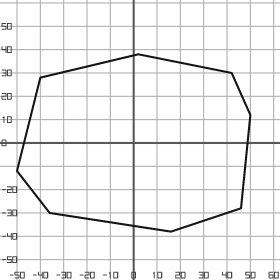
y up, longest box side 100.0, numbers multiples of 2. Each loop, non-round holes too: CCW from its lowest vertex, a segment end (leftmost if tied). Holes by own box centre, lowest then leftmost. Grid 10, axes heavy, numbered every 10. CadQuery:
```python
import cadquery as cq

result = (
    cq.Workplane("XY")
    .moveTo(16.0, -38.0)
    .lineTo(46.0, -28.0)
    .lineTo(50.0, 12.0)
    .lineTo(42.0, 30.0)
    .lineTo(2.0, 38.0)
    .lineTo(-40.0, 28.0)
    .lineTo(-50.0, -12.0)
    .lineTo(-36.0, -30.0)
    .close()
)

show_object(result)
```